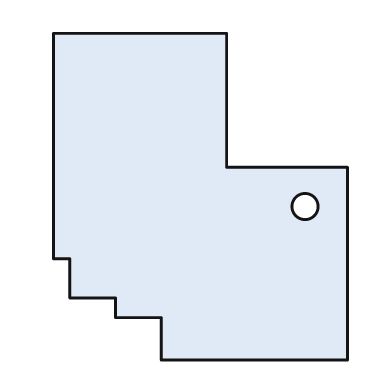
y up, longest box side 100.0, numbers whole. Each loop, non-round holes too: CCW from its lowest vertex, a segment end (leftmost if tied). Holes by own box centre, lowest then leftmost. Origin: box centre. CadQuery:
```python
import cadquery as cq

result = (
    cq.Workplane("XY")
    .moveTo(-12.0, -50.0)
    .lineTo(45.0, -50.0)
    .lineTo(45.0, 9.0)
    .lineTo(8.0, 9.0)
    .lineTo(8.0, 50.0)
    .lineTo(-45.0, 50.0)
    .lineTo(-45.0, -19.0)
    .lineTo(-40.0, -19.0)
    .lineTo(-40.0, -31.0)
    .lineTo(-26.0, -31.0)
    .lineTo(-26.0, -37.0)
    .lineTo(-12.0, -37.0)
    .close()
    .moveTo(32.0, -3.0)
    .circle(4.0)
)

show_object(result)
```